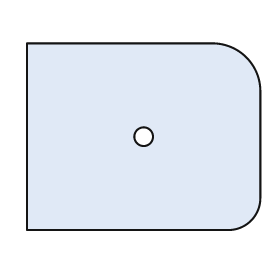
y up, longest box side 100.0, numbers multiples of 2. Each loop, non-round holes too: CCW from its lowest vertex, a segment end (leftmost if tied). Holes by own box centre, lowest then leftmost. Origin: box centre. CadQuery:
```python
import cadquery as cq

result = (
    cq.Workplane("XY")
    .moveTo(-50.0, -40.0)
    .lineTo(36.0, -40.0)
    .threePointArc((46.0, -36.0), (50.0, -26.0))
    .lineTo(50.0, 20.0)
    .threePointArc((44.0, 34.0), (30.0, 40.0))
    .lineTo(-50.0, 40.0)
    .close()
    .moveTo(0.0, 0.0)
    .circle(4.0)
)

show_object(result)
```